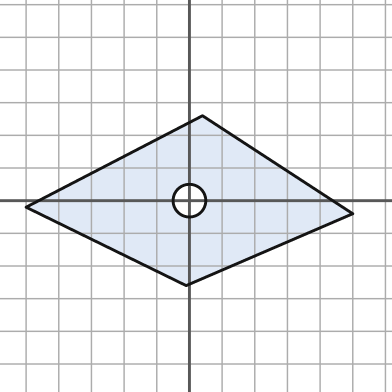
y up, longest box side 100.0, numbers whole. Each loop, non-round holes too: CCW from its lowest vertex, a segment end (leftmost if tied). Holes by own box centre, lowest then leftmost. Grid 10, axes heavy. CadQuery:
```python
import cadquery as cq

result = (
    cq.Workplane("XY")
    .moveTo(-1.0, -26.0)
    .lineTo(50.0, -4.0)
    .lineTo(4.0, 26.0)
    .lineTo(-50.0, -2.0)
    .close()
    .moveTo(0.0, 0.0)
    .circle(5.0)
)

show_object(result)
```